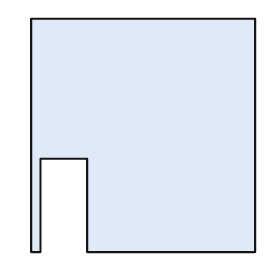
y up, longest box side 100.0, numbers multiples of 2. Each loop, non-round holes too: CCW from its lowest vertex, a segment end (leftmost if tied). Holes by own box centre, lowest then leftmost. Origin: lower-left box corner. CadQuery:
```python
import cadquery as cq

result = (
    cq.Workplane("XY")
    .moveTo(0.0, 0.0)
    .lineTo(4.0, 0.0)
    .lineTo(4.0, 40.0)
    .lineTo(24.0, 40.0)
    .lineTo(24.0, 0.0)
    .lineTo(96.0, 0.0)
    .lineTo(96.0, 100.0)
    .lineTo(0.0, 100.0)
    .close()
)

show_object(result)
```